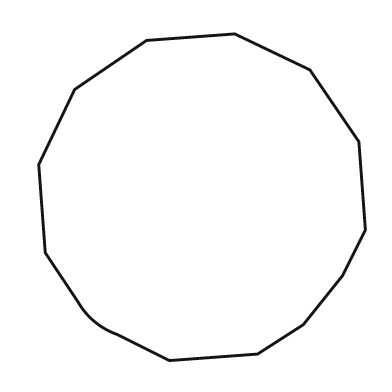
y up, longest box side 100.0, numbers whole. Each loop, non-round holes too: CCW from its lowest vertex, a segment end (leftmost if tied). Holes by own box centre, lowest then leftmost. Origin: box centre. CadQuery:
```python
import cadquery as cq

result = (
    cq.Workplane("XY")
    .moveTo(-10.0, -50.0)
    .lineTo(17.0, -48.0)
    .lineTo(31.0, -39.0)
    .lineTo(43.0, -24.0)
    .lineTo(50.0, -10.0)
    .lineTo(48.0, 17.0)
    .lineTo(33.0, 39.0)
    .lineTo(10.0, 50.0)
    .lineTo(-17.0, 48.0)
    .lineTo(-39.0, 33.0)
    .lineTo(-50.0, 10.0)
    .lineTo(-48.0, -17.0)
    .lineTo(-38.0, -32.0)
    .threePointArc((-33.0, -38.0), (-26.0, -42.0))
    .close()
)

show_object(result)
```